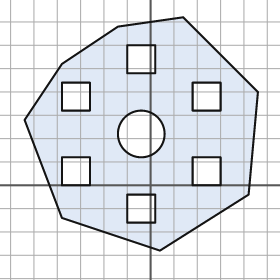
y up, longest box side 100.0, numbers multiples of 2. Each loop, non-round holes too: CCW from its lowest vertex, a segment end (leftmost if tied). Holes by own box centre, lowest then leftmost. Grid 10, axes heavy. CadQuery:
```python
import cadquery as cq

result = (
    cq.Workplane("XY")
    .moveTo(4.0, -28.0)
    .lineTo(42.0, -4.0)
    .lineTo(46.0, 40.0)
    .lineTo(14.0, 72.0)
    .lineTo(-14.0, 68.0)
    .lineTo(-38.0, 52.0)
    .lineTo(-54.0, 28.0)
    .lineTo(-38.0, -14.0)
    .close()
    .moveTo(-10.0, -16.0)
    .lineTo(2.0, -16.0)
    .lineTo(2.0, -4.0)
    .lineTo(-10.0, -4.0)
    .close()
    .moveTo(-38.0, 0.0)
    .lineTo(-26.0, 0.0)
    .lineTo(-26.0, 12.0)
    .lineTo(-38.0, 12.0)
    .close()
    .moveTo(18.0, 0.0)
    .lineTo(30.0, 0.0)
    .lineTo(30.0, 12.0)
    .lineTo(18.0, 12.0)
    .close()
    .moveTo(-4.0, 22.0)
    .circle(10.0)
    .moveTo(-38.0, 32.0)
    .lineTo(-26.0, 32.0)
    .lineTo(-26.0, 44.0)
    .lineTo(-38.0, 44.0)
    .close()
    .moveTo(18.0, 32.0)
    .lineTo(30.0, 32.0)
    .lineTo(30.0, 44.0)
    .lineTo(18.0, 44.0)
    .close()
    .moveTo(-10.0, 48.0)
    .lineTo(2.0, 48.0)
    .lineTo(2.0, 60.0)
    .lineTo(-10.0, 60.0)
    .close()
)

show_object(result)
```